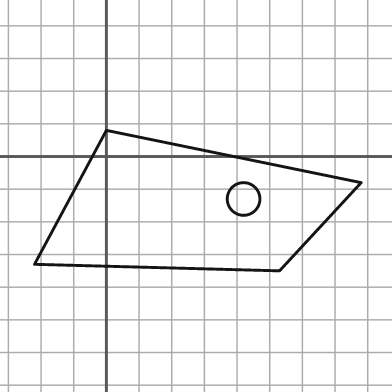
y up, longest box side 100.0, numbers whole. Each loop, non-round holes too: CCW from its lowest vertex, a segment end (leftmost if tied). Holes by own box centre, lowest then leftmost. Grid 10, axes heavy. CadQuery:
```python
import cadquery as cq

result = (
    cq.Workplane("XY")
    .moveTo(53.0, -35.0)
    .lineTo(78.0, -8.0)
    .lineTo(0.0, 8.0)
    .lineTo(-22.0, -33.0)
    .close()
    .moveTo(42.0, -13.0)
    .circle(5.0)
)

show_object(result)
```